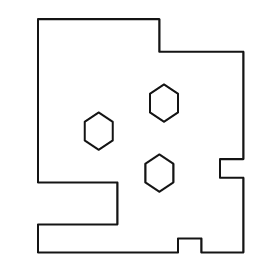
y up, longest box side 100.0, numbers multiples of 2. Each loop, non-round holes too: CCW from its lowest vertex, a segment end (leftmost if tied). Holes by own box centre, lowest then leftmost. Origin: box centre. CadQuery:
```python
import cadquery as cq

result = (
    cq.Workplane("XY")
    .moveTo(-44.0, -50.0)
    .lineTo(16.0, -50.0)
    .lineTo(16.0, -44.0)
    .lineTo(26.0, -44.0)
    .lineTo(26.0, -50.0)
    .lineTo(44.0, -50.0)
    .lineTo(44.0, -18.0)
    .lineTo(34.0, -18.0)
    .lineTo(34.0, -10.0)
    .lineTo(44.0, -10.0)
    .lineTo(44.0, 36.0)
    .lineTo(8.0, 36.0)
    .lineTo(8.0, 50.0)
    .lineTo(-44.0, 50.0)
    .lineTo(-44.0, -20.0)
    .lineTo(-10.0, -20.0)
    .lineTo(-10.0, -38.0)
    .lineTo(-44.0, -38.0)
    .close()
    .moveTo(8.0, -24.0)
    .lineTo(14.0, -20.0)
    .lineTo(14.0, -12.0)
    .lineTo(8.0, -8.0)
    .lineTo(2.0, -12.0)
    .lineTo(2.0, -20.0)
    .close()
    .moveTo(-18.0, -6.0)
    .lineTo(-12.0, -2.0)
    .lineTo(-12.0, 6.0)
    .lineTo(-18.0, 10.0)
    .lineTo(-24.0, 6.0)
    .lineTo(-24.0, -2.0)
    .close()
    .moveTo(10.0, 6.0)
    .lineTo(16.0, 10.0)
    .lineTo(16.0, 18.0)
    .lineTo(10.0, 22.0)
    .lineTo(4.0, 18.0)
    .lineTo(4.0, 10.0)
    .close()
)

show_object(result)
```